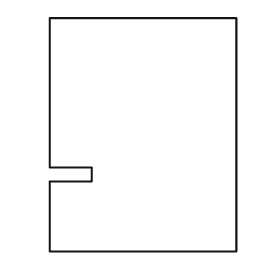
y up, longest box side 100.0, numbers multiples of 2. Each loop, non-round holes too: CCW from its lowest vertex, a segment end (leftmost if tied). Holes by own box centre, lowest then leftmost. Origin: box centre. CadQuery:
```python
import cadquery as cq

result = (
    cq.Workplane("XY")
    .moveTo(-40.0, -50.0)
    .lineTo(40.0, -50.0)
    .lineTo(40.0, 50.0)
    .lineTo(-40.0, 50.0)
    .lineTo(-40.0, -14.0)
    .lineTo(-22.0, -14.0)
    .lineTo(-22.0, -20.0)
    .lineTo(-40.0, -20.0)
    .close()
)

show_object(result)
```